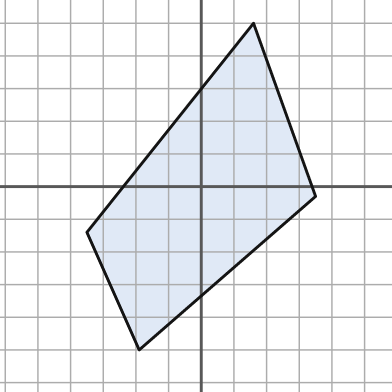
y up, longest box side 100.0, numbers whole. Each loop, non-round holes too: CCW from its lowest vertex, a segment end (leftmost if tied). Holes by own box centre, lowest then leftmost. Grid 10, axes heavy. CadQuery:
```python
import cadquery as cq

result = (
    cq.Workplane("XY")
    .moveTo(-19.0, -50.0)
    .lineTo(35.0, -3.0)
    .lineTo(16.0, 50.0)
    .lineTo(-35.0, -14.0)
    .close()
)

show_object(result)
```